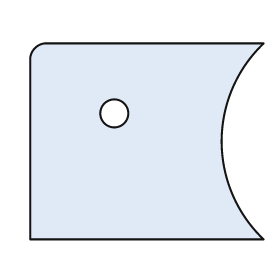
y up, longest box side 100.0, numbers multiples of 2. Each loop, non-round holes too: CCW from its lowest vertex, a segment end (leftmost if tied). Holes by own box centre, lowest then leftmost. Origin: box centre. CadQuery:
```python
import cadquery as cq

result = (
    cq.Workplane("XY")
    .moveTo(-50.0, -42.0)
    .lineTo(50.0, -42.0)
    .threePointArc((32.0, 0.0), (50.0, 42.0))
    .lineTo(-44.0, 42.0)
    .threePointArc((-48.0, 40.0), (-50.0, 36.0))
    .close()
    .moveTo(-14.0, 12.0)
    .circle(6.0)
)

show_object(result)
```